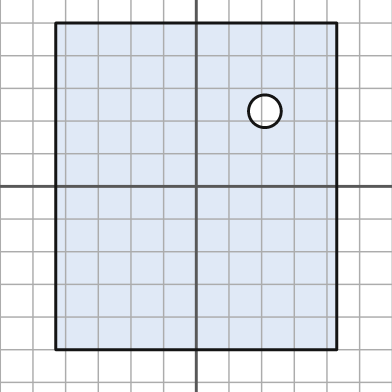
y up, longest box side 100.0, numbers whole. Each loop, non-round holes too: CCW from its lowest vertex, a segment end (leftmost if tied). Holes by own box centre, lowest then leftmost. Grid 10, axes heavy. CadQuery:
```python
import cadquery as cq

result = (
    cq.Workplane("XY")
    .moveTo(-43.0, -50.0)
    .lineTo(43.0, -50.0)
    .lineTo(43.0, 50.0)
    .lineTo(-43.0, 50.0)
    .close()
    .moveTo(21.0, 23.0)
    .circle(5.0)
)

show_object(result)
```